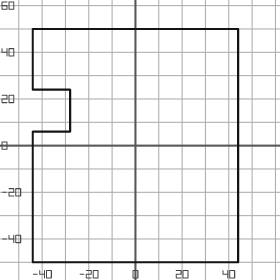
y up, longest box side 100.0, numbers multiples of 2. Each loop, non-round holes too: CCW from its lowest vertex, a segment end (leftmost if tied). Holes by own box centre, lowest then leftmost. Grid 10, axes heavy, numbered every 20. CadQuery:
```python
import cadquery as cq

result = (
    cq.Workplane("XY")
    .moveTo(-44.0, -50.0)
    .lineTo(44.0, -50.0)
    .lineTo(44.0, 50.0)
    .lineTo(-44.0, 50.0)
    .lineTo(-44.0, 24.0)
    .lineTo(-28.0, 24.0)
    .lineTo(-28.0, 6.0)
    .lineTo(-44.0, 6.0)
    .close()
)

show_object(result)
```